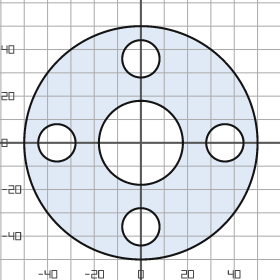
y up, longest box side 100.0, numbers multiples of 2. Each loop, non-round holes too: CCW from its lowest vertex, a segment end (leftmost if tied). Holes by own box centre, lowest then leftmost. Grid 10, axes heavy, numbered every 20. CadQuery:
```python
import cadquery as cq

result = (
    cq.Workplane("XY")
    .moveTo(0.0, 0.0)
    .circle(50.0)
    .moveTo(0.0, -36.0)
    .circle(8.0)
    .moveTo(-36.0, 0.0)
    .circle(8.0)
    .moveTo(0.0, 0.0)
    .circle(18.0)
    .moveTo(36.0, 0.0)
    .circle(8.0)
    .moveTo(0.0, 36.0)
    .circle(8.0)
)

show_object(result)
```